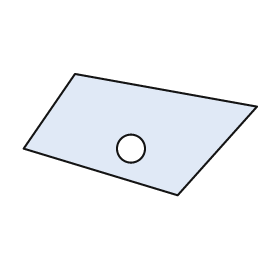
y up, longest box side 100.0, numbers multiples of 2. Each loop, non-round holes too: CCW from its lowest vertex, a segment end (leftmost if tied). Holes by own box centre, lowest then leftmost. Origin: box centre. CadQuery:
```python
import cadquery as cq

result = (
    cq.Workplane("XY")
    .moveTo(16.0, -26.0)
    .lineTo(50.0, 12.0)
    .lineTo(-28.0, 26.0)
    .lineTo(-50.0, -6.0)
    .close()
    .moveTo(-4.0, -6.0)
    .circle(6.0)
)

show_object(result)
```